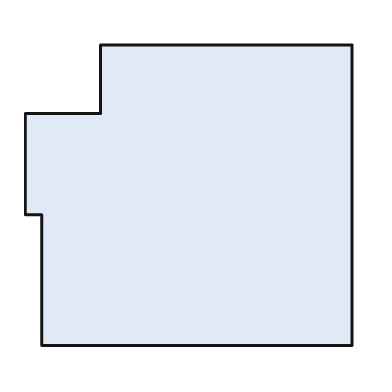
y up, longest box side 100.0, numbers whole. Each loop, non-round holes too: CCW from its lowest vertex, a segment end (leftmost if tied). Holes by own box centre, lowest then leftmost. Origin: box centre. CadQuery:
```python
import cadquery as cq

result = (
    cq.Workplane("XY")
    .moveTo(-45.0, -46.0)
    .lineTo(50.0, -46.0)
    .lineTo(50.0, 46.0)
    .lineTo(-27.0, 46.0)
    .lineTo(-27.0, 25.0)
    .lineTo(-50.0, 25.0)
    .lineTo(-50.0, -6.0)
    .lineTo(-45.0, -6.0)
    .close()
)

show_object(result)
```